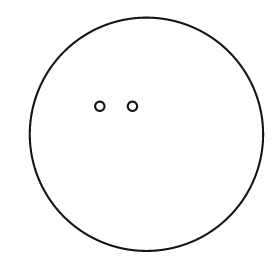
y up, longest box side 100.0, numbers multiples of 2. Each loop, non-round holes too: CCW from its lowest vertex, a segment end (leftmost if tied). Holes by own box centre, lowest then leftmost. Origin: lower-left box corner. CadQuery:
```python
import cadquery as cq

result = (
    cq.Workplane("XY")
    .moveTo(50.0, 50.0)
    .circle(50.0)
    .moveTo(30.0, 62.0)
    .circle(2.0)
    .moveTo(44.0, 62.0)
    .circle(2.0)
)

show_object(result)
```